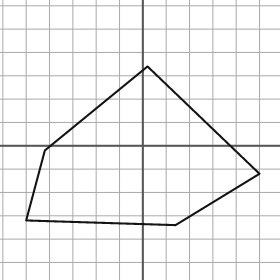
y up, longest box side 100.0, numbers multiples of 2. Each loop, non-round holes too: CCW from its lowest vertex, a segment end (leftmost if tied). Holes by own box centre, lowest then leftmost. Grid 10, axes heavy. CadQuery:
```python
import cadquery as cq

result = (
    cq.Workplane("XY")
    .moveTo(14.0, -34.0)
    .lineTo(50.0, -12.0)
    .lineTo(2.0, 34.0)
    .lineTo(-42.0, -2.0)
    .lineTo(-50.0, -32.0)
    .close()
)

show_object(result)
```